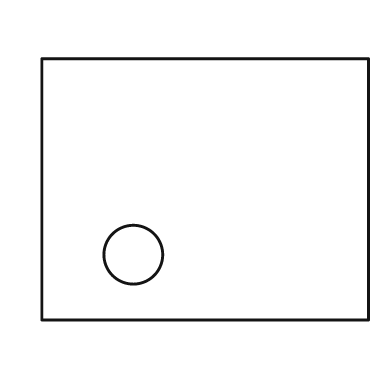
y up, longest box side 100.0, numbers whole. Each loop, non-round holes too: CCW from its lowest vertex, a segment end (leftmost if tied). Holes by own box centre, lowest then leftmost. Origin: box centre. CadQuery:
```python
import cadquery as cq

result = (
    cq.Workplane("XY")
    .moveTo(-50.0, -40.0)
    .lineTo(50.0, -40.0)
    .lineTo(50.0, 40.0)
    .lineTo(-50.0, 40.0)
    .close()
    .moveTo(-22.0, -20.0)
    .circle(9.0)
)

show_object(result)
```